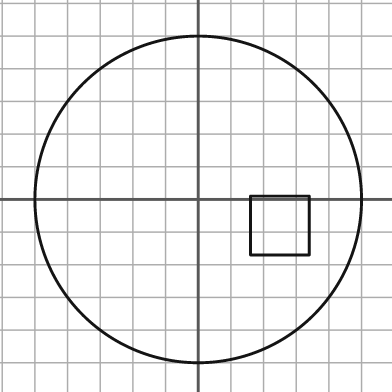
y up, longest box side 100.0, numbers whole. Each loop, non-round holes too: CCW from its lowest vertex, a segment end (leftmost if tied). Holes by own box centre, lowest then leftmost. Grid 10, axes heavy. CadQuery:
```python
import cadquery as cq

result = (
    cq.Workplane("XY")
    .moveTo(0.0, 0.0)
    .circle(50.0)
    .moveTo(16.0, -17.0)
    .lineTo(34.0, -17.0)
    .lineTo(34.0, 1.0)
    .lineTo(16.0, 1.0)
    .close()
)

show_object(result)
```